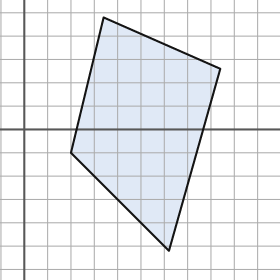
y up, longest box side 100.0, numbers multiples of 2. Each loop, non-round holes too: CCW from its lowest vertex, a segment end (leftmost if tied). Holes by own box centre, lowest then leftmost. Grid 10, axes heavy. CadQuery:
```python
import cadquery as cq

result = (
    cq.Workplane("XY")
    .moveTo(62.0, -52.0)
    .lineTo(84.0, 26.0)
    .lineTo(34.0, 48.0)
    .lineTo(20.0, -10.0)
    .close()
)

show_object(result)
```